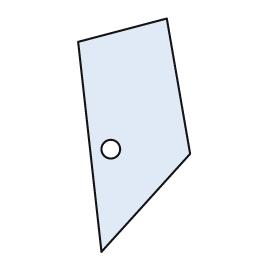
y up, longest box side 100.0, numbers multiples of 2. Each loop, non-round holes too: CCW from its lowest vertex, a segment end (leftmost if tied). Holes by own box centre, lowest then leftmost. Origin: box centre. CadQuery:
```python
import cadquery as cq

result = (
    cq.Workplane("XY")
    .moveTo(-14.0, -50.0)
    .lineTo(24.0, -8.0)
    .lineTo(14.0, 50.0)
    .lineTo(-24.0, 40.0)
    .close()
    .moveTo(-10.0, -6.0)
    .circle(4.0)
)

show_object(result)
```